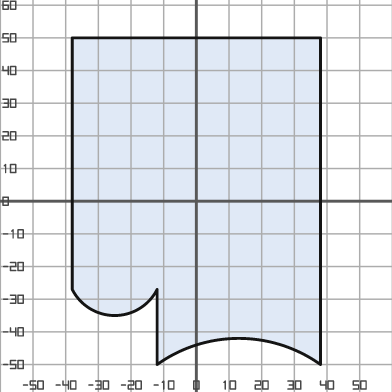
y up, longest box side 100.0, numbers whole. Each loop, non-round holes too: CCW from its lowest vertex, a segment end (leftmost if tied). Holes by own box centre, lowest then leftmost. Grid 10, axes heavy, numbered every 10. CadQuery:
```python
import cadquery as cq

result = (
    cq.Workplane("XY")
    .moveTo(-12.0, -50.0)
    .threePointArc((13.0, -42.0), (38.0, -50.0))
    .lineTo(38.0, 50.0)
    .lineTo(-38.0, 50.0)
    .lineTo(-38.0, -27.0)
    .threePointArc((-25.0, -35.0), (-12.0, -27.0))
    .close()
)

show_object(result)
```